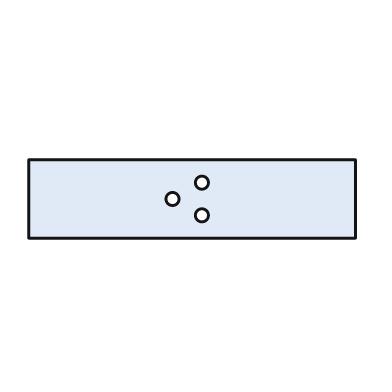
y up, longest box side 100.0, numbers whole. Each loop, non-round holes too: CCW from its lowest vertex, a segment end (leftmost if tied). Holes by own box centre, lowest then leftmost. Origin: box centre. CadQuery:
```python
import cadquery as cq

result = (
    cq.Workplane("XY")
    .moveTo(-50.0, -12.0)
    .lineTo(50.0, -12.0)
    .lineTo(50.0, 12.0)
    .lineTo(-50.0, 12.0)
    .close()
    .moveTo(3.0, -5.0)
    .circle(2.0)
    .moveTo(-6.0, 0.0)
    .circle(2.0)
    .moveTo(3.0, 5.0)
    .circle(2.0)
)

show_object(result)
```